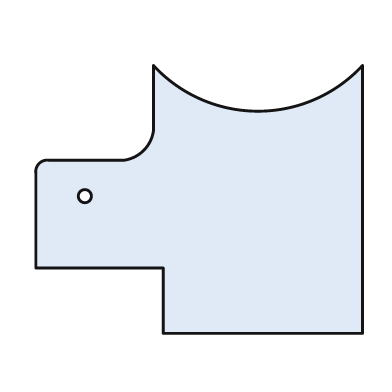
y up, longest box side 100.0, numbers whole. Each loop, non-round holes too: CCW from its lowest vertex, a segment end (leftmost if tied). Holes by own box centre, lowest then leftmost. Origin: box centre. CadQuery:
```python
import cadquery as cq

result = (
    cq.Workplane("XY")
    .moveTo(-11.0, -41.0)
    .lineTo(50.0, -41.0)
    .lineTo(50.0, 41.0)
    .threePointArc((18.0, 27.0), (-14.0, 41.0))
    .lineTo(-14.0, 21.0)
    .threePointArc((-17.0, 15.0), (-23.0, 12.0))
    .lineTo(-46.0, 12.0)
    .threePointArc((-49.0, 11.0), (-50.0, 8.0))
    .lineTo(-50.0, -21.0)
    .lineTo(-11.0, -21.0)
    .close()
    .moveTo(-35.0, 1.0)
    .circle(2.0)
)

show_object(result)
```